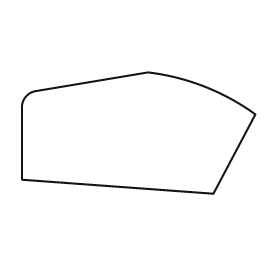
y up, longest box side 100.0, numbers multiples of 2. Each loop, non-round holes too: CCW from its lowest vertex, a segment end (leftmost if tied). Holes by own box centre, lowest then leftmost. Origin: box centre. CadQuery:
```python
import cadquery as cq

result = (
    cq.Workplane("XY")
    .moveTo(32.0, -26.0)
    .lineTo(50.0, 8.0)
    .threePointArc((28.0, 20.0), (4.0, 26.0))
    .lineTo(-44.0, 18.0)
    .threePointArc((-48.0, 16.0), (-50.0, 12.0))
    .lineTo(-50.0, -20.0)
    .close()
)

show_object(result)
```